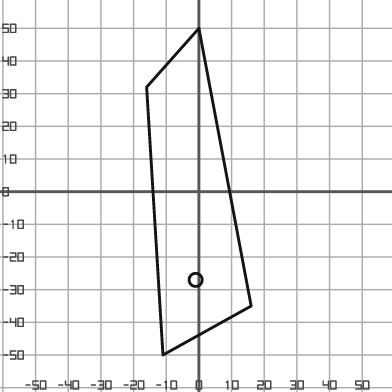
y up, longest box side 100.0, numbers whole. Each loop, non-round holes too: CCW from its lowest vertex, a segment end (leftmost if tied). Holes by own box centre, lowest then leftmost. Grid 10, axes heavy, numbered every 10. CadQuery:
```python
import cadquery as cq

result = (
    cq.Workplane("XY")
    .moveTo(-11.0, -50.0)
    .lineTo(16.0, -35.0)
    .lineTo(0.0, 50.0)
    .lineTo(-16.0, 32.0)
    .close()
    .moveTo(-1.0, -27.0)
    .circle(2.0)
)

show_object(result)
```